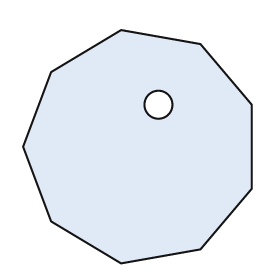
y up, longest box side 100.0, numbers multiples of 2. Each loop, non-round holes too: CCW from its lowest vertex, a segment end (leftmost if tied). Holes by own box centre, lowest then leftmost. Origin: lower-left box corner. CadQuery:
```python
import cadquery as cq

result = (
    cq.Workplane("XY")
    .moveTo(42.0, 0.0)
    .lineTo(76.0, 6.0)
    .lineTo(98.0, 32.0)
    .lineTo(98.0, 68.0)
    .lineTo(76.0, 94.0)
    .lineTo(42.0, 100.0)
    .lineTo(12.0, 82.0)
    .lineTo(0.0, 50.0)
    .lineTo(12.0, 18.0)
    .close()
    .moveTo(58.0, 68.0)
    .circle(6.0)
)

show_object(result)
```